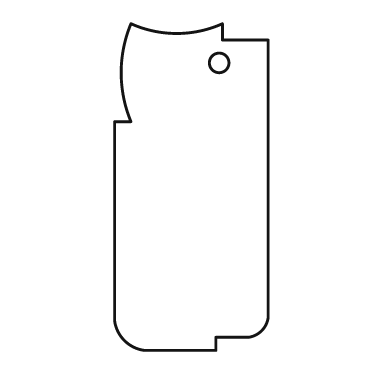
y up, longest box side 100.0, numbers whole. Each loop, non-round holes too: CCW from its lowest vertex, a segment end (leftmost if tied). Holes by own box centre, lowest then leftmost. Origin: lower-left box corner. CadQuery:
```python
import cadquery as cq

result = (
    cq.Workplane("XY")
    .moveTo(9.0, 0.0)
    .lineTo(31.0, 0.0)
    .lineTo(31.0, 4.0)
    .lineTo(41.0, 4.0)
    .threePointArc((45.0, 6.0), (47.0, 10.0))
    .lineTo(47.0, 95.0)
    .lineTo(33.0, 95.0)
    .lineTo(33.0, 100.0)
    .threePointArc((19.0, 97.0), (5.0, 100.0))
    .threePointArc((2.0, 85.0), (5.0, 70.0))
    .lineTo(0.0, 70.0)
    .lineTo(0.0, 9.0)
    .threePointArc((3.0, 3.0), (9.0, 0.0))
    .close()
    .moveTo(32.0, 88.0)
    .circle(3.0)
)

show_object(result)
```